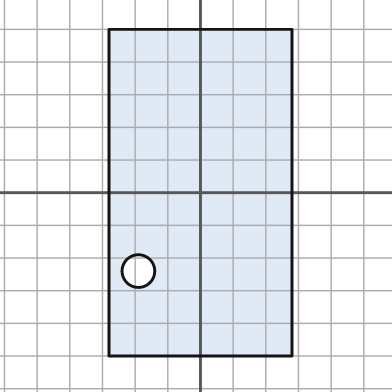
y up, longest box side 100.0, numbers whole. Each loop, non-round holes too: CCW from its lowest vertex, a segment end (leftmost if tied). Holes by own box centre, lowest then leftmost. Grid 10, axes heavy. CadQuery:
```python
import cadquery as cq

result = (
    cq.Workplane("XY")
    .moveTo(-28.0, -50.0)
    .lineTo(28.0, -50.0)
    .lineTo(28.0, 50.0)
    .lineTo(-28.0, 50.0)
    .close()
    .moveTo(-19.0, -24.0)
    .circle(5.0)
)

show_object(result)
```